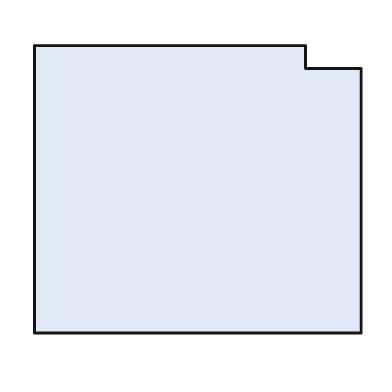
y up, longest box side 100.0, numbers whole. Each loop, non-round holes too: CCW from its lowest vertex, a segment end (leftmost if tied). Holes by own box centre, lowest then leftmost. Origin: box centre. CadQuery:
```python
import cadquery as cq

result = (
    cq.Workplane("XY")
    .moveTo(-50.0, -44.0)
    .lineTo(50.0, -44.0)
    .lineTo(50.0, 37.0)
    .lineTo(33.0, 37.0)
    .lineTo(33.0, 44.0)
    .lineTo(-50.0, 44.0)
    .close()
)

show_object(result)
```